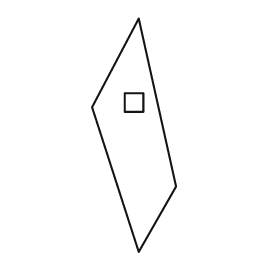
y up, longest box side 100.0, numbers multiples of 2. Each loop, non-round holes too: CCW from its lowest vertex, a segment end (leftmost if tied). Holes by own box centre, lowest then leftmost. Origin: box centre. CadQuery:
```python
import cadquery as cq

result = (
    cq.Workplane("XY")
    .moveTo(2.0, -50.0)
    .lineTo(18.0, -22.0)
    .lineTo(2.0, 50.0)
    .lineTo(-18.0, 12.0)
    .close()
    .moveTo(-4.0, 10.0)
    .lineTo(4.0, 10.0)
    .lineTo(4.0, 18.0)
    .lineTo(-4.0, 18.0)
    .close()
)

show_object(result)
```